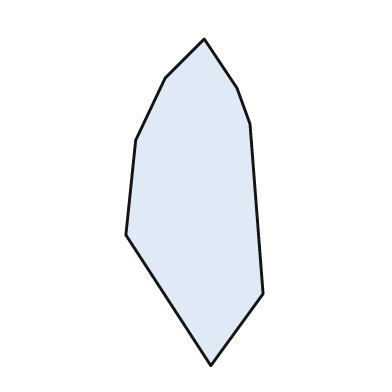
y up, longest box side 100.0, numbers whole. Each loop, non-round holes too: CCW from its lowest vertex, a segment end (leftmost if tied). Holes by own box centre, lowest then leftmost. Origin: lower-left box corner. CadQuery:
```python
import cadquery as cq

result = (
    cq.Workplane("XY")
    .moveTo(26.0, 0.0)
    .lineTo(42.0, 22.0)
    .lineTo(38.0, 74.0)
    .lineTo(34.0, 85.0)
    .lineTo(24.0, 100.0)
    .lineTo(12.0, 88.0)
    .lineTo(3.0, 69.0)
    .lineTo(0.0, 40.0)
    .close()
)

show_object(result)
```